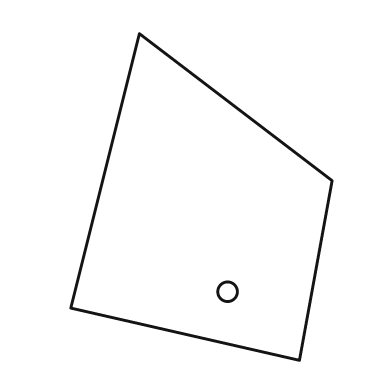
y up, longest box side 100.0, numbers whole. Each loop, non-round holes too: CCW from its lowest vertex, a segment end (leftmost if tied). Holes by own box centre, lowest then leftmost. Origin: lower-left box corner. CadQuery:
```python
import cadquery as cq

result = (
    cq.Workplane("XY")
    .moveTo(70.0, 0.0)
    .lineTo(80.0, 55.0)
    .lineTo(21.0, 100.0)
    .lineTo(0.0, 16.0)
    .close()
    .moveTo(48.0, 21.0)
    .circle(3.0)
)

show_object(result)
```